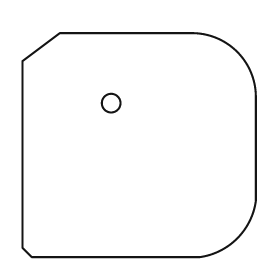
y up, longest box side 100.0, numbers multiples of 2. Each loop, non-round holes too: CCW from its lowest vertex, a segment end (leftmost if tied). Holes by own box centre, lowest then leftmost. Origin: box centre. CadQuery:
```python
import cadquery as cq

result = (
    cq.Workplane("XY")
    .moveTo(-46.0, -48.0)
    .lineTo(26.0, -48.0)
    .threePointArc((42.0, -40.0), (50.0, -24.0))
    .lineTo(50.0, 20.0)
    .threePointArc((42.0, 40.0), (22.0, 48.0))
    .lineTo(-34.0, 48.0)
    .lineTo(-50.0, 36.0)
    .lineTo(-50.0, -44.0)
    .close()
    .moveTo(-12.0, 18.0)
    .circle(4.0)
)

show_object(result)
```